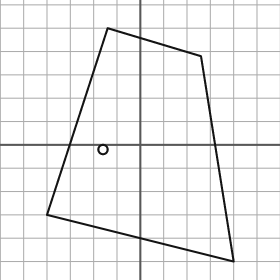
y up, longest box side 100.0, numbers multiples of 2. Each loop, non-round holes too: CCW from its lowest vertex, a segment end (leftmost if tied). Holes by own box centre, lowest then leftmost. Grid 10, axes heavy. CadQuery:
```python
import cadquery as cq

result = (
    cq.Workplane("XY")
    .moveTo(40.0, -50.0)
    .lineTo(26.0, 38.0)
    .lineTo(-14.0, 50.0)
    .lineTo(-40.0, -30.0)
    .close()
    .moveTo(-16.0, -2.0)
    .circle(2.0)
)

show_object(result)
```